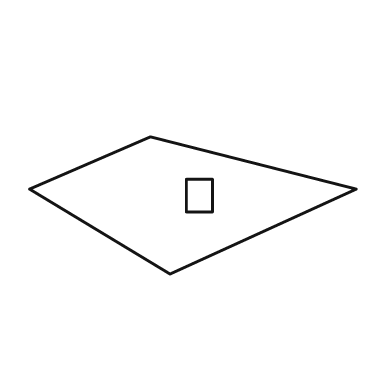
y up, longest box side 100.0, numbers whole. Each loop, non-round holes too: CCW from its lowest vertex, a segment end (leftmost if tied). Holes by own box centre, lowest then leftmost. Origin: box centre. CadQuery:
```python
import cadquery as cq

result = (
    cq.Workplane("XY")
    .moveTo(-7.0, -21.0)
    .lineTo(50.0, 5.0)
    .lineTo(-13.0, 21.0)
    .lineTo(-50.0, 5.0)
    .close()
    .moveTo(-2.0, -2.0)
    .lineTo(6.0, -2.0)
    .lineTo(6.0, 8.0)
    .lineTo(-2.0, 8.0)
    .close()
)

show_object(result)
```